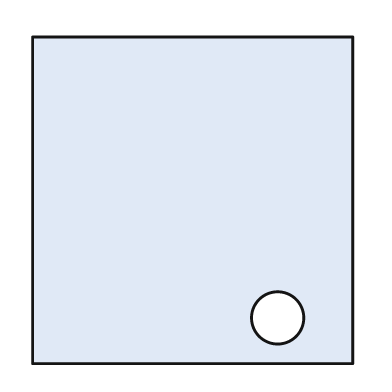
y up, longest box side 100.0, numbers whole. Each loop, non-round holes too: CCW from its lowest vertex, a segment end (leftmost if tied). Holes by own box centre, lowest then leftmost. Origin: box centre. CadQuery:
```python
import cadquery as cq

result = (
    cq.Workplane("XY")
    .moveTo(-49.0, -50.0)
    .lineTo(49.0, -50.0)
    .lineTo(49.0, 50.0)
    .lineTo(-49.0, 50.0)
    .close()
    .moveTo(26.0, -36.0)
    .circle(8.0)
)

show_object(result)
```